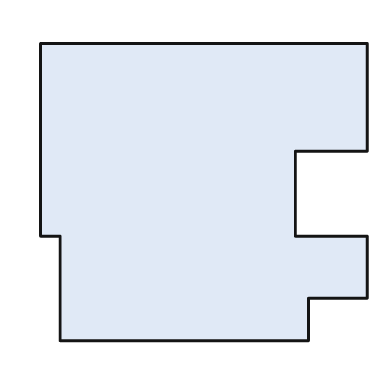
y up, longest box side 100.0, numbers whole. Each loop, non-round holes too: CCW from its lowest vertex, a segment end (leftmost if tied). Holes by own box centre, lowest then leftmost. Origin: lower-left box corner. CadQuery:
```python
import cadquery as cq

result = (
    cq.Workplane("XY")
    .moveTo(6.0, 0.0)
    .lineTo(82.0, 0.0)
    .lineTo(82.0, 13.0)
    .lineTo(100.0, 13.0)
    .lineTo(100.0, 32.0)
    .lineTo(78.0, 32.0)
    .lineTo(78.0, 58.0)
    .lineTo(100.0, 58.0)
    .lineTo(100.0, 91.0)
    .lineTo(0.0, 91.0)
    .lineTo(0.0, 32.0)
    .lineTo(6.0, 32.0)
    .close()
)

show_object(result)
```